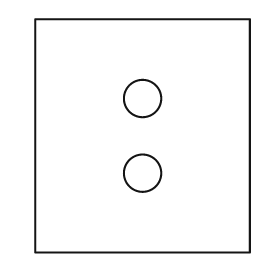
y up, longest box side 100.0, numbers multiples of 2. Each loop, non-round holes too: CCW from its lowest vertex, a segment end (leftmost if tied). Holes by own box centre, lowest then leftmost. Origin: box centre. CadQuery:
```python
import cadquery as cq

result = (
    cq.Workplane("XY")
    .moveTo(-46.0, -50.0)
    .lineTo(46.0, -50.0)
    .lineTo(46.0, 50.0)
    .lineTo(-46.0, 50.0)
    .close()
    .moveTo(0.0, -16.0)
    .circle(8.0)
    .moveTo(0.0, 16.0)
    .circle(8.0)
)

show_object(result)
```